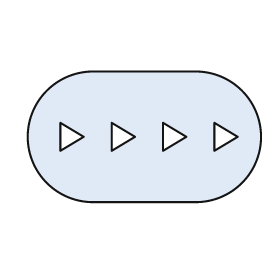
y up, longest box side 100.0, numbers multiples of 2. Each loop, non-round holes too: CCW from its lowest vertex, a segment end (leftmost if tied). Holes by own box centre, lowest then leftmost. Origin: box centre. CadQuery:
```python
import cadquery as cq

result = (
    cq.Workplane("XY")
    .moveTo(-22.0, -28.0)
    .lineTo(22.0, -28.0)
    .threePointArc((50.0, 0.0), (22.0, 28.0))
    .lineTo(-22.0, 28.0)
    .threePointArc((-50.0, 0.0), (-22.0, -28.0))
    .close()
    .moveTo(-36.0, -6.0)
    .lineTo(-26.0, 0.0)
    .lineTo(-36.0, 6.0)
    .close()
    .moveTo(-14.0, -6.0)
    .lineTo(-4.0, 0.0)
    .lineTo(-14.0, 6.0)
    .close()
    .moveTo(8.0, -6.0)
    .lineTo(18.0, 0.0)
    .lineTo(8.0, 6.0)
    .close()
    .moveTo(30.0, -6.0)
    .lineTo(40.0, 0.0)
    .lineTo(30.0, 6.0)
    .close()
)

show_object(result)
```